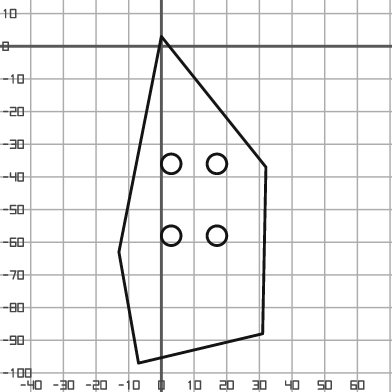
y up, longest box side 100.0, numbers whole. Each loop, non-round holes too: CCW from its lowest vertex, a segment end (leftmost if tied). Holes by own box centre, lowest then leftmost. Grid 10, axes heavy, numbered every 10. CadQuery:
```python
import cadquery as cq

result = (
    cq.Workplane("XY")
    .moveTo(-7.0, -97.0)
    .lineTo(31.0, -88.0)
    .lineTo(32.0, -37.0)
    .lineTo(0.0, 3.0)
    .lineTo(-13.0, -63.0)
    .close()
    .moveTo(3.0, -58.0)
    .circle(3.0)
    .moveTo(17.0, -58.0)
    .circle(3.0)
    .moveTo(3.0, -36.0)
    .circle(3.0)
    .moveTo(17.0, -36.0)
    .circle(3.0)
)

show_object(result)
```